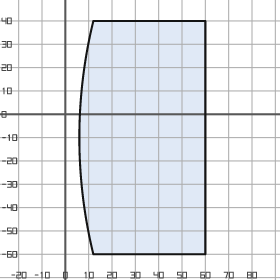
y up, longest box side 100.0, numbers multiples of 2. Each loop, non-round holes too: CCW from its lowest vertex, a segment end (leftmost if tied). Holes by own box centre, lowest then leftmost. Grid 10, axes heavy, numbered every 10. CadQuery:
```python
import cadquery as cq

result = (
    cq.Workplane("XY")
    .moveTo(12.0, -60.0)
    .lineTo(60.0, -60.0)
    .lineTo(60.0, 40.0)
    .lineTo(12.0, 40.0)
    .threePointArc((6.0, -10.0), (12.0, -60.0))
    .close()
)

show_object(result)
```